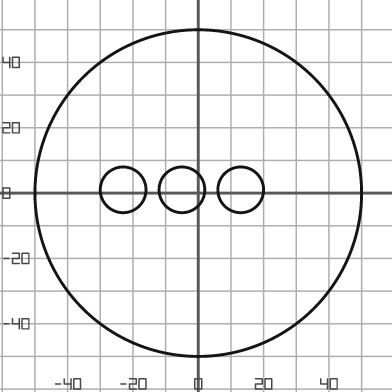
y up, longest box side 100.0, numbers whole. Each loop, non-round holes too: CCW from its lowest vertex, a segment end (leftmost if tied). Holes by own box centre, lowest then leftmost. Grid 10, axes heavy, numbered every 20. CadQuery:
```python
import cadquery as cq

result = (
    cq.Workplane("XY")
    .moveTo(0.0, 0.0)
    .circle(50.0)
    .moveTo(-23.0, 1.0)
    .circle(7.0)
    .moveTo(-5.0, 1.0)
    .circle(7.0)
    .moveTo(13.0, 1.0)
    .circle(7.0)
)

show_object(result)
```